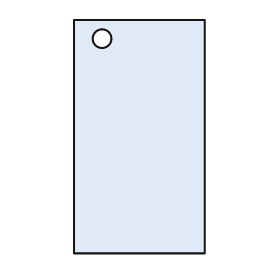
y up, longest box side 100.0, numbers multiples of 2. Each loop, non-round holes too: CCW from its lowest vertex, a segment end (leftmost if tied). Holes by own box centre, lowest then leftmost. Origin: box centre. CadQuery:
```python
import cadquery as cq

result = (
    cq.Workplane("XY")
    .moveTo(-28.0, -50.0)
    .lineTo(28.0, -50.0)
    .lineTo(28.0, 50.0)
    .lineTo(-28.0, 50.0)
    .close()
    .moveTo(-16.0, 42.0)
    .circle(4.0)
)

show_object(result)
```